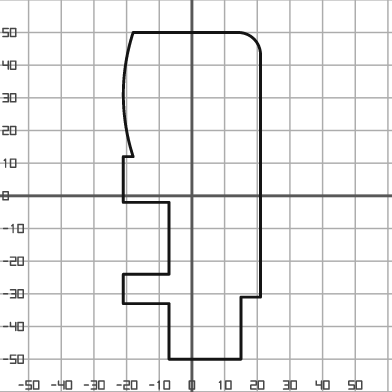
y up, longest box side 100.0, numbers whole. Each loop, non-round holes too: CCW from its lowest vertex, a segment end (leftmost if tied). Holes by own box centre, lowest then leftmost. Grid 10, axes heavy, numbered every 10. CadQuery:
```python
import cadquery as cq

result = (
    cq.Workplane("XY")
    .moveTo(-7.0, -50.0)
    .lineTo(15.0, -50.0)
    .lineTo(15.0, -31.0)
    .lineTo(21.0, -31.0)
    .lineTo(21.0, 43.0)
    .threePointArc((19.0, 48.0), (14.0, 50.0))
    .lineTo(-18.0, 50.0)
    .threePointArc((-21.0, 31.0), (-18.0, 12.0))
    .lineTo(-21.0, 12.0)
    .lineTo(-21.0, -2.0)
    .lineTo(-7.0, -2.0)
    .lineTo(-7.0, -24.0)
    .lineTo(-21.0, -24.0)
    .lineTo(-21.0, -33.0)
    .lineTo(-7.0, -33.0)
    .close()
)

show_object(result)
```